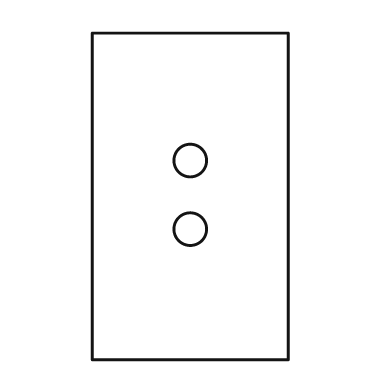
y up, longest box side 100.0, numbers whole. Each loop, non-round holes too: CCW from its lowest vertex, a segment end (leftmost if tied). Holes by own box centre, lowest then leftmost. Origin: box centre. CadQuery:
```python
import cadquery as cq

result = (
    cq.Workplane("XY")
    .moveTo(-30.0, -50.0)
    .lineTo(30.0, -50.0)
    .lineTo(30.0, 50.0)
    .lineTo(-30.0, 50.0)
    .close()
    .moveTo(0.0, -10.0)
    .circle(5.0)
    .moveTo(0.0, 11.0)
    .circle(5.0)
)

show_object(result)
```